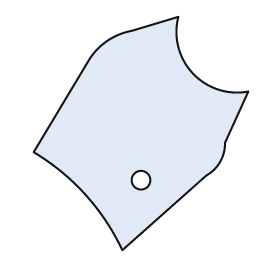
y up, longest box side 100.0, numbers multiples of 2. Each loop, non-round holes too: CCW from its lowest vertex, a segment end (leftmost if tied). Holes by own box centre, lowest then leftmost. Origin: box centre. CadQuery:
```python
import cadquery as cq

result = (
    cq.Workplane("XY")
    .moveTo(-8.0, -50.0)
    .lineTo(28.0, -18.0)
    .threePointArc((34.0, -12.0), (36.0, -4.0))
    .lineTo(46.0, 18.0)
    .threePointArc((22.0, 26.0), (16.0, 50.0))
    .lineTo(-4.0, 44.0)
    .threePointArc((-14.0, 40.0), (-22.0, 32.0))
    .lineTo(-46.0, -8.0)
    .threePointArc((-24.0, -26.0), (-8.0, -50.0))
    .close()
    .moveTo(0.0, -20.0)
    .circle(4.0)
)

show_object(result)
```